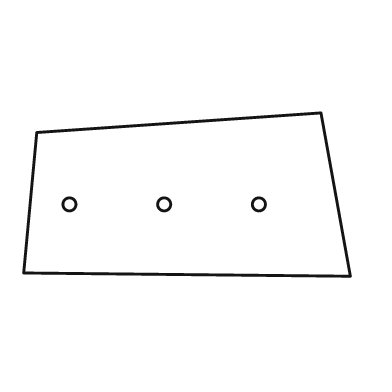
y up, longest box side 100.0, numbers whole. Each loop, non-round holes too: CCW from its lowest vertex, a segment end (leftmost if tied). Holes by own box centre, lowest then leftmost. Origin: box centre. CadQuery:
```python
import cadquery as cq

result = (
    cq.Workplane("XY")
    .moveTo(50.0, -25.0)
    .lineTo(41.0, 25.0)
    .lineTo(-46.0, 19.0)
    .lineTo(-50.0, -24.0)
    .close()
    .moveTo(-36.0, -3.0)
    .circle(2.0)
    .moveTo(-7.0, -3.0)
    .circle(2.0)
    .moveTo(22.0, -3.0)
    .circle(2.0)
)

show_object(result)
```